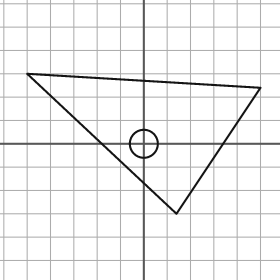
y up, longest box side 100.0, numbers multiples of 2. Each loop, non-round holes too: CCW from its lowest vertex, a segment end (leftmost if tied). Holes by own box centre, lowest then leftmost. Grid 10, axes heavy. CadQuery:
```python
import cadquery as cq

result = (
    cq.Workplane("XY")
    .moveTo(14.0, -30.0)
    .lineTo(50.0, 24.0)
    .lineTo(-50.0, 30.0)
    .close()
    .moveTo(0.0, 0.0)
    .circle(6.0)
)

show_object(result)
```